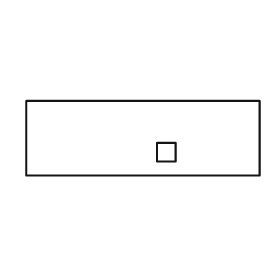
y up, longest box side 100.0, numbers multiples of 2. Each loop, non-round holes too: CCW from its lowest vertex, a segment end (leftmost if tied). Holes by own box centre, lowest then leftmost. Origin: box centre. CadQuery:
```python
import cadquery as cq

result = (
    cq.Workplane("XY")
    .moveTo(-50.0, -16.0)
    .lineTo(50.0, -16.0)
    .lineTo(50.0, 16.0)
    .lineTo(-50.0, 16.0)
    .close()
    .moveTo(6.0, -10.0)
    .lineTo(14.0, -10.0)
    .lineTo(14.0, -2.0)
    .lineTo(6.0, -2.0)
    .close()
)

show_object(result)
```